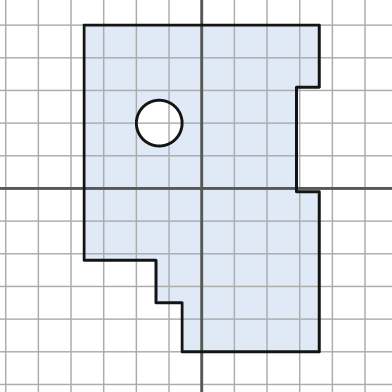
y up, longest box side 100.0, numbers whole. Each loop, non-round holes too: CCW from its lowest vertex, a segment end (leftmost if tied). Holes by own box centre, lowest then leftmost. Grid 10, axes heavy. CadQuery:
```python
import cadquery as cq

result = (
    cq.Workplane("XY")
    .moveTo(-6.0, -50.0)
    .lineTo(36.0, -50.0)
    .lineTo(36.0, -1.0)
    .lineTo(29.0, -1.0)
    .lineTo(29.0, 31.0)
    .lineTo(36.0, 31.0)
    .lineTo(36.0, 50.0)
    .lineTo(-36.0, 50.0)
    .lineTo(-36.0, -22.0)
    .lineTo(-14.0, -22.0)
    .lineTo(-14.0, -35.0)
    .lineTo(-6.0, -35.0)
    .close()
    .moveTo(-13.0, 20.0)
    .circle(7.0)
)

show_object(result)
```